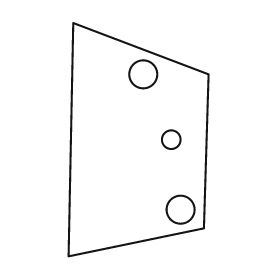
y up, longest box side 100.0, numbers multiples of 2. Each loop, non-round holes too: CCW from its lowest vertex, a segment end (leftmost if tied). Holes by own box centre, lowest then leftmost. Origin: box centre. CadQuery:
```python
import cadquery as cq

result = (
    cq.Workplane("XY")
    .moveTo(-30.0, -50.0)
    .lineTo(28.0, -38.0)
    .lineTo(30.0, 28.0)
    .lineTo(-28.0, 50.0)
    .close()
    .moveTo(18.0, -30.0)
    .circle(6.0)
    .moveTo(14.0, 0.0)
    .circle(4.0)
    .moveTo(2.0, 28.0)
    .circle(6.0)
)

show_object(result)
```